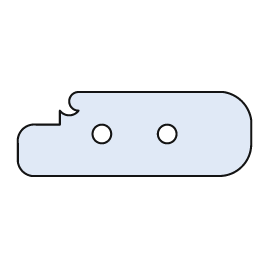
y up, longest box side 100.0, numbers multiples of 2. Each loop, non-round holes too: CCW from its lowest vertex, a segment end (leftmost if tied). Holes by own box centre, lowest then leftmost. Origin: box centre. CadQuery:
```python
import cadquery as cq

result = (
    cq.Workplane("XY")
    .moveTo(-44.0, -18.0)
    .lineTo(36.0, -18.0)
    .threePointArc((46.0, -14.0), (50.0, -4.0))
    .lineTo(50.0, 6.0)
    .threePointArc((46.0, 14.0), (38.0, 18.0))
    .lineTo(-24.0, 18.0)
    .threePointArc((-28.0, 14.0), (-24.0, 10.0))
    .threePointArc((-28.0, 8.0), (-32.0, 10.0))
    .lineTo(-32.0, 4.0)
    .lineTo(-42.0, 4.0)
    .threePointArc((-48.0, 2.0), (-50.0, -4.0))
    .lineTo(-50.0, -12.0)
    .threePointArc((-48.0, -16.0), (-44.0, -18.0))
    .close()
    .moveTo(-14.0, 0.0)
    .circle(4.0)
    .moveTo(14.0, 0.0)
    .circle(4.0)
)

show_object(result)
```